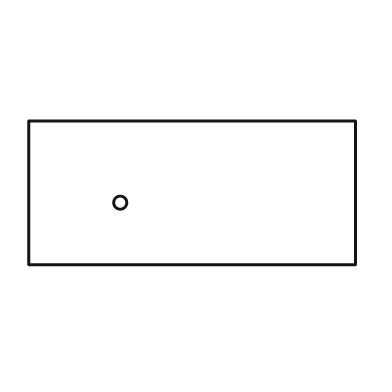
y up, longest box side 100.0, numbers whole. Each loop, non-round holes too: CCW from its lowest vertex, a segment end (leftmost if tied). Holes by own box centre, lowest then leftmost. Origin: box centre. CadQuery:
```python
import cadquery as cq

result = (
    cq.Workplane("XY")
    .moveTo(-50.0, -22.0)
    .lineTo(50.0, -22.0)
    .lineTo(50.0, 22.0)
    .lineTo(-50.0, 22.0)
    .close()
    .moveTo(-22.0, -3.0)
    .circle(2.0)
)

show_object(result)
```